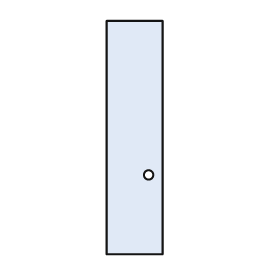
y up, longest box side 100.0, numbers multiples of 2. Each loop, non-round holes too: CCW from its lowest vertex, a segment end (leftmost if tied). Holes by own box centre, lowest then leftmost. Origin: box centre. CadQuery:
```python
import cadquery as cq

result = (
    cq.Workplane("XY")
    .moveTo(-12.0, -50.0)
    .lineTo(12.0, -50.0)
    .lineTo(12.0, 50.0)
    .lineTo(-12.0, 50.0)
    .close()
    .moveTo(6.0, -16.0)
    .circle(2.0)
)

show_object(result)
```